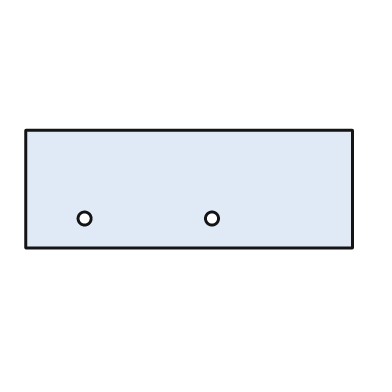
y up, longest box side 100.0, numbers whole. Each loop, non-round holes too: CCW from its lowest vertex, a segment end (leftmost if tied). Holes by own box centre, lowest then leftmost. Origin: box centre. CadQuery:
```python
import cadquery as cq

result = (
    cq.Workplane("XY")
    .moveTo(-50.0, -18.0)
    .lineTo(50.0, -18.0)
    .lineTo(50.0, 18.0)
    .lineTo(-50.0, 18.0)
    .close()
    .moveTo(-32.0, -9.0)
    .circle(2.0)
    .moveTo(7.0, -9.0)
    .circle(2.0)
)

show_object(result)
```